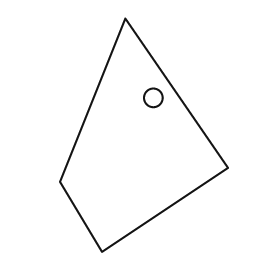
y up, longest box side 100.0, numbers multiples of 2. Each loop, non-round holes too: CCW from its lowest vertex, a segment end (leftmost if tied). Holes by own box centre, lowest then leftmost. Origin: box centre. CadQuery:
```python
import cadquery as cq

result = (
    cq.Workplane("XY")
    .moveTo(-18.0, -50.0)
    .lineTo(36.0, -14.0)
    .lineTo(-8.0, 50.0)
    .lineTo(-36.0, -20.0)
    .close()
    .moveTo(4.0, 16.0)
    .circle(4.0)
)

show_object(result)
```